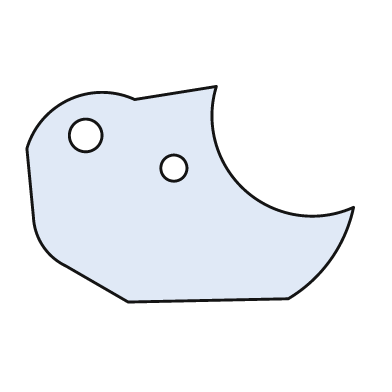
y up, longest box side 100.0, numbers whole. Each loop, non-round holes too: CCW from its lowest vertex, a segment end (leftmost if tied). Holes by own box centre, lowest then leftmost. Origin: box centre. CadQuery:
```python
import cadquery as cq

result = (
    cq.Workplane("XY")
    .moveTo(-19.0, -33.0)
    .lineTo(30.0, -32.0)
    .threePointArc((43.0, -20.0), (50.0, -4.0))
    .threePointArc((17.0, 1.0), (8.0, 33.0))
    .lineTo(-17.0, 29.0)
    .threePointArc((-37.0, 29.0), (-50.0, 14.0))
    .lineTo(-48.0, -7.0)
    .threePointArc((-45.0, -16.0), (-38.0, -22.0))
    .close()
    .moveTo(-5.0, 8.0)
    .circle(4.0)
    .moveTo(-32.0, 18.0)
    .circle(5.0)
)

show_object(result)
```